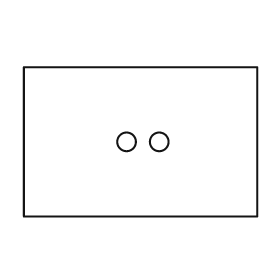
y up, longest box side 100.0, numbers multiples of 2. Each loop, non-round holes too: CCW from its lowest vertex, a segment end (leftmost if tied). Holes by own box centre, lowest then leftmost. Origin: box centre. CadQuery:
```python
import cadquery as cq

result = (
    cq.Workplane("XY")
    .moveTo(-50.0, -32.0)
    .lineTo(50.0, -32.0)
    .lineTo(50.0, 32.0)
    .lineTo(-50.0, 32.0)
    .close()
    .moveTo(-6.0, 0.0)
    .circle(4.0)
    .moveTo(8.0, 0.0)
    .circle(4.0)
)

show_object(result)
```